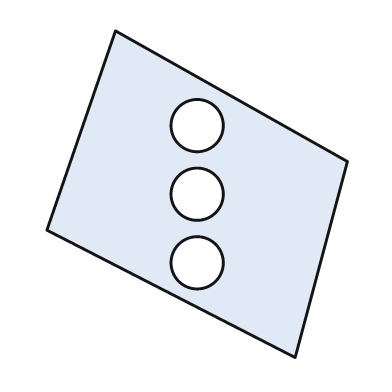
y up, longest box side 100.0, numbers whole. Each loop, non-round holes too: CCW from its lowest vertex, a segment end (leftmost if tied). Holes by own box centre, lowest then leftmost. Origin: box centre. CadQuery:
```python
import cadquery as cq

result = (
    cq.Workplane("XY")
    .moveTo(30.0, -50.0)
    .lineTo(46.0, 10.0)
    .lineTo(-25.0, 50.0)
    .lineTo(-46.0, -11.0)
    .close()
    .moveTo(0.0, -21.0)
    .circle(8.0)
    .moveTo(0.0, 0.0)
    .circle(8.0)
    .moveTo(0.0, 21.0)
    .circle(8.0)
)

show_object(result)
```